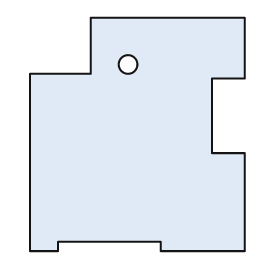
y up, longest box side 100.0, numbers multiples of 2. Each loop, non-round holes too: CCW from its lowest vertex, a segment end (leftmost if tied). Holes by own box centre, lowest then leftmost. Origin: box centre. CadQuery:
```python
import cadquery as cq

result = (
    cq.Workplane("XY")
    .moveTo(-46.0, -50.0)
    .lineTo(-34.0, -50.0)
    .lineTo(-34.0, -46.0)
    .lineTo(10.0, -46.0)
    .lineTo(10.0, -50.0)
    .lineTo(46.0, -50.0)
    .lineTo(46.0, -8.0)
    .lineTo(32.0, -8.0)
    .lineTo(32.0, 24.0)
    .lineTo(46.0, 24.0)
    .lineTo(46.0, 50.0)
    .lineTo(-20.0, 50.0)
    .lineTo(-20.0, 26.0)
    .lineTo(-46.0, 26.0)
    .close()
    .moveTo(-4.0, 30.0)
    .circle(4.0)
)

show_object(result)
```